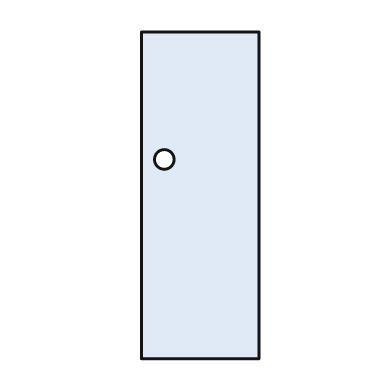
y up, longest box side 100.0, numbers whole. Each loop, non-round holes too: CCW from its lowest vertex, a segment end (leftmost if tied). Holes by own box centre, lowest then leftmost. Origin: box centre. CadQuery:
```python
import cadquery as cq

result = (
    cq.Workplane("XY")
    .moveTo(-18.0, -50.0)
    .lineTo(18.0, -50.0)
    .lineTo(18.0, 50.0)
    .lineTo(-18.0, 50.0)
    .close()
    .moveTo(-11.0, 11.0)
    .circle(3.0)
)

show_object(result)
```